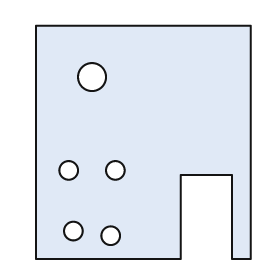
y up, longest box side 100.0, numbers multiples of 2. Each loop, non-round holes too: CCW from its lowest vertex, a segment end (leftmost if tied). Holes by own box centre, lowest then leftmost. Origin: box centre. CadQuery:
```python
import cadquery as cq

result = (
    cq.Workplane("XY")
    .moveTo(-46.0, -50.0)
    .lineTo(16.0, -50.0)
    .lineTo(16.0, -14.0)
    .lineTo(38.0, -14.0)
    .lineTo(38.0, -50.0)
    .lineTo(46.0, -50.0)
    .lineTo(46.0, 50.0)
    .lineTo(-46.0, 50.0)
    .close()
    .moveTo(-14.0, -40.0)
    .circle(4.0)
    .moveTo(-30.0, -38.0)
    .circle(4.0)
    .moveTo(-32.0, -12.0)
    .circle(4.0)
    .moveTo(-12.0, -12.0)
    .circle(4.0)
    .moveTo(-22.0, 28.0)
    .circle(6.0)
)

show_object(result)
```